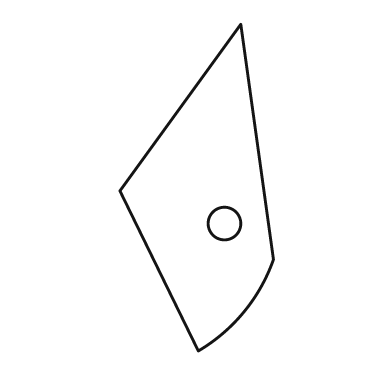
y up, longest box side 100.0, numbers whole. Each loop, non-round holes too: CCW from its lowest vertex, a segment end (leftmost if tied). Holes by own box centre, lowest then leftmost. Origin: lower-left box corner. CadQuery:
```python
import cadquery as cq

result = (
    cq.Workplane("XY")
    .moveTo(24.0, 0.0)
    .threePointArc((38.0, 12.0), (47.0, 28.0))
    .lineTo(37.0, 100.0)
    .lineTo(0.0, 49.0)
    .close()
    .moveTo(32.0, 39.0)
    .circle(5.0)
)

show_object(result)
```